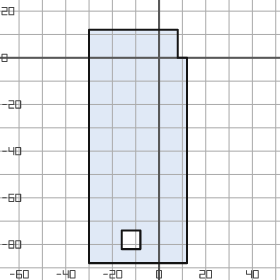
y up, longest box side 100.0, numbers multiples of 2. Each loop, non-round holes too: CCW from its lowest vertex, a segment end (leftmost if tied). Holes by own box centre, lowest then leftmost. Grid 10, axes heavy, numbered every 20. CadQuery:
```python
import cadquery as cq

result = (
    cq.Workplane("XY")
    .moveTo(-30.0, -88.0)
    .lineTo(12.0, -88.0)
    .lineTo(12.0, 0.0)
    .lineTo(8.0, 0.0)
    .lineTo(8.0, 12.0)
    .lineTo(-30.0, 12.0)
    .close()
    .moveTo(-16.0, -82.0)
    .lineTo(-8.0, -82.0)
    .lineTo(-8.0, -74.0)
    .lineTo(-16.0, -74.0)
    .close()
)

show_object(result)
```